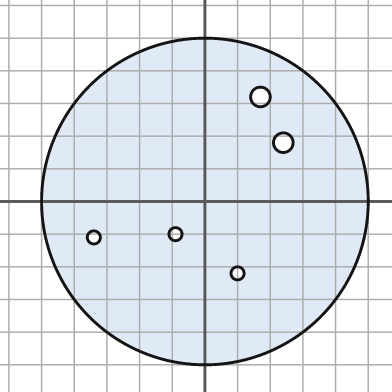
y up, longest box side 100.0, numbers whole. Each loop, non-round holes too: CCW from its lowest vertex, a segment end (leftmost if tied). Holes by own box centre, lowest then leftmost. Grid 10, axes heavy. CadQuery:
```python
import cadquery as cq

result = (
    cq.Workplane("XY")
    .moveTo(0.0, 0.0)
    .circle(50.0)
    .moveTo(10.0, -22.0)
    .circle(2.0)
    .moveTo(-34.0, -11.0)
    .circle(2.0)
    .moveTo(-9.0, -10.0)
    .circle(2.0)
    .moveTo(24.0, 18.0)
    .circle(3.0)
    .moveTo(17.0, 32.0)
    .circle(3.0)
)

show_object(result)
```